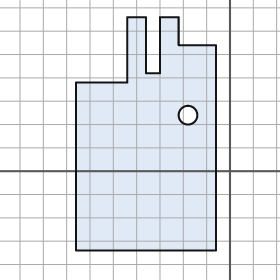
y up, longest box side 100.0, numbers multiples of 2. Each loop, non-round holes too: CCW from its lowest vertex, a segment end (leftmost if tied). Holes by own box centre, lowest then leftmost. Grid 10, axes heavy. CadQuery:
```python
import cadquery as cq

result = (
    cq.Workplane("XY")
    .moveTo(-66.0, -34.0)
    .lineTo(-6.0, -34.0)
    .lineTo(-6.0, 54.0)
    .lineTo(-22.0, 54.0)
    .lineTo(-22.0, 66.0)
    .lineTo(-30.0, 66.0)
    .lineTo(-30.0, 42.0)
    .lineTo(-36.0, 42.0)
    .lineTo(-36.0, 66.0)
    .lineTo(-44.0, 66.0)
    .lineTo(-44.0, 38.0)
    .lineTo(-66.0, 38.0)
    .close()
    .moveTo(-18.0, 24.0)
    .circle(4.0)
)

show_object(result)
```